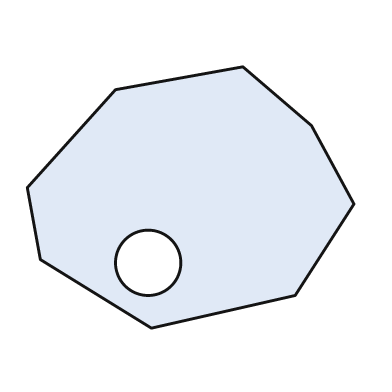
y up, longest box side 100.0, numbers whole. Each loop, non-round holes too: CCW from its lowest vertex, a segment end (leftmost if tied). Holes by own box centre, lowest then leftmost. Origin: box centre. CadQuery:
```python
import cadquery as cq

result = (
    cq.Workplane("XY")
    .moveTo(-12.0, -40.0)
    .lineTo(32.0, -30.0)
    .lineTo(50.0, -2.0)
    .lineTo(37.0, 22.0)
    .lineTo(16.0, 40.0)
    .lineTo(-23.0, 33.0)
    .lineTo(-50.0, 3.0)
    .lineTo(-46.0, -19.0)
    .close()
    .moveTo(-13.0, -20.0)
    .circle(10.0)
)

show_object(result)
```